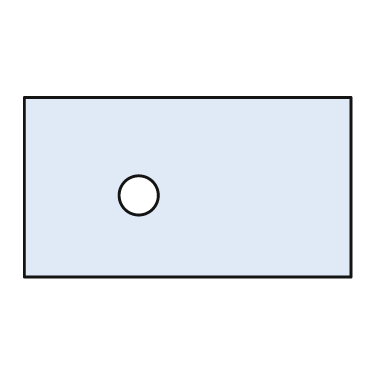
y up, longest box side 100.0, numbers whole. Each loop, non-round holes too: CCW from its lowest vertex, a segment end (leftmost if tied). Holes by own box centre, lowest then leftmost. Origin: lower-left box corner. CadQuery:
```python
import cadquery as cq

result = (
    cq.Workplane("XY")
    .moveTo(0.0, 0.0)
    .lineTo(100.0, 0.0)
    .lineTo(100.0, 55.0)
    .lineTo(0.0, 55.0)
    .close()
    .moveTo(35.0, 25.0)
    .circle(6.0)
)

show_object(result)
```